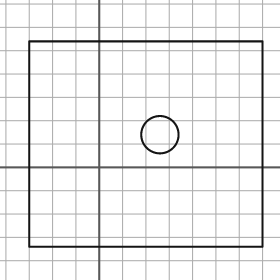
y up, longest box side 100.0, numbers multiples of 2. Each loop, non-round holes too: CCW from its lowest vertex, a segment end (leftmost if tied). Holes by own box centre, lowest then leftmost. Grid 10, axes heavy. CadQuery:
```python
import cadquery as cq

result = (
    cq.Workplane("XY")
    .moveTo(-30.0, -34.0)
    .lineTo(70.0, -34.0)
    .lineTo(70.0, 54.0)
    .lineTo(-30.0, 54.0)
    .close()
    .moveTo(26.0, 14.0)
    .circle(8.0)
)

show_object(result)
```